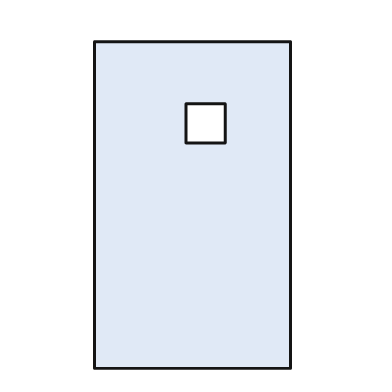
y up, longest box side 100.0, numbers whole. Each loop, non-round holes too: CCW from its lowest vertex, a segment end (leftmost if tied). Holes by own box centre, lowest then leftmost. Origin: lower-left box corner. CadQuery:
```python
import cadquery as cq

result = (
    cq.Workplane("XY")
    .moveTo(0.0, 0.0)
    .lineTo(60.0, 0.0)
    .lineTo(60.0, 100.0)
    .lineTo(0.0, 100.0)
    .close()
    .moveTo(28.0, 69.0)
    .lineTo(40.0, 69.0)
    .lineTo(40.0, 81.0)
    .lineTo(28.0, 81.0)
    .close()
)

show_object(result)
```